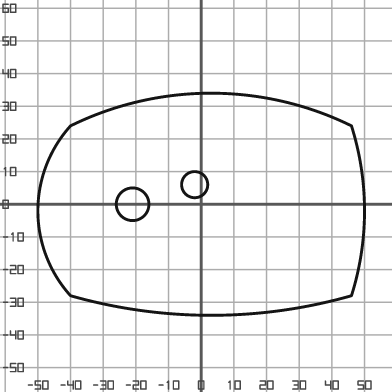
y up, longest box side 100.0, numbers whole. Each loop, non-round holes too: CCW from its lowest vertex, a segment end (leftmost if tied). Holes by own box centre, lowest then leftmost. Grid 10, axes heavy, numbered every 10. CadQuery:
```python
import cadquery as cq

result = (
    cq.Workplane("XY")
    .moveTo(-40.0, -28.0)
    .threePointArc((3.0, -34.0), (46.0, -28.0))
    .threePointArc((50.0, -2.0), (46.0, 24.0))
    .threePointArc((3.0, 34.0), (-40.0, 24.0))
    .threePointArc((-50.0, -2.0), (-40.0, -28.0))
    .close()
    .moveTo(-21.0, 0.0)
    .circle(5.0)
    .moveTo(-2.0, 6.0)
    .circle(4.0)
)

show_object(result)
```